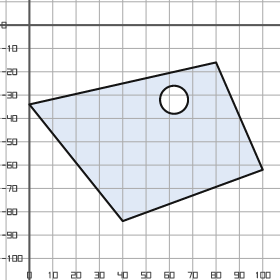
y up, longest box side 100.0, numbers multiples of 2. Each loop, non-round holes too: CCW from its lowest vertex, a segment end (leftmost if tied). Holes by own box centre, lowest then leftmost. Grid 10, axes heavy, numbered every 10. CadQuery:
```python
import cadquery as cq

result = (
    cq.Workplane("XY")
    .moveTo(40.0, -84.0)
    .lineTo(100.0, -62.0)
    .lineTo(80.0, -16.0)
    .lineTo(0.0, -34.0)
    .close()
    .moveTo(62.0, -32.0)
    .circle(6.0)
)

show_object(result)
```